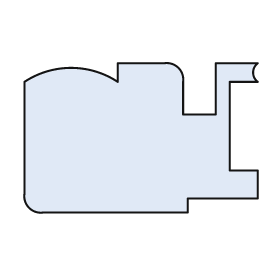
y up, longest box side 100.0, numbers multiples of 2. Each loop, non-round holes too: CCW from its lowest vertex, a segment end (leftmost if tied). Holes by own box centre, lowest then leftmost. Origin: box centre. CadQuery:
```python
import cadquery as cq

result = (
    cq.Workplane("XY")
    .moveTo(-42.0, -32.0)
    .lineTo(20.0, -32.0)
    .lineTo(20.0, -26.0)
    .lineTo(50.0, -26.0)
    .lineTo(50.0, -14.0)
    .lineTo(38.0, -14.0)
    .lineTo(38.0, 24.0)
    .lineTo(50.0, 24.0)
    .threePointArc((48.0, 28.0), (50.0, 32.0))
    .lineTo(32.0, 32.0)
    .lineTo(32.0, 10.0)
    .lineTo(18.0, 10.0)
    .lineTo(18.0, 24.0)
    .threePointArc((16.0, 30.0), (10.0, 32.0))
    .lineTo(-10.0, 32.0)
    .lineTo(-10.0, 24.0)
    .threePointArc((-30.0, 30.0), (-50.0, 24.0))
    .lineTo(-50.0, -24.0)
    .threePointArc((-48.0, -30.0), (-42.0, -32.0))
    .close()
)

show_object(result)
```